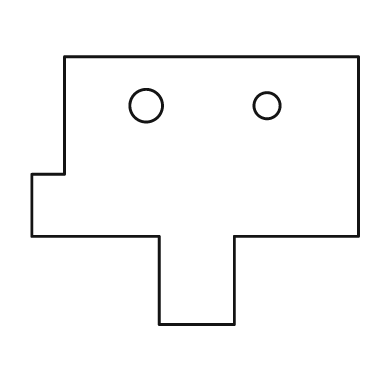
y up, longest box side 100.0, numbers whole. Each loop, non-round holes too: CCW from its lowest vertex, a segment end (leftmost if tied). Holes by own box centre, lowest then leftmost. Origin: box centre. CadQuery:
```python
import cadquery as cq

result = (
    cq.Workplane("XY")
    .moveTo(-11.0, -41.0)
    .lineTo(12.0, -41.0)
    .lineTo(12.0, -14.0)
    .lineTo(50.0, -14.0)
    .lineTo(50.0, 41.0)
    .lineTo(-40.0, 41.0)
    .lineTo(-40.0, 5.0)
    .lineTo(-50.0, 5.0)
    .lineTo(-50.0, -14.0)
    .lineTo(-11.0, -14.0)
    .close()
    .moveTo(-15.0, 26.0)
    .circle(5.0)
    .moveTo(22.0, 26.0)
    .circle(4.0)
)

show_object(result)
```